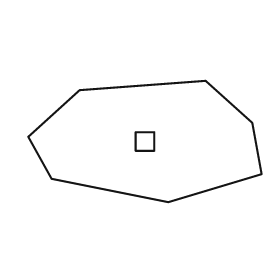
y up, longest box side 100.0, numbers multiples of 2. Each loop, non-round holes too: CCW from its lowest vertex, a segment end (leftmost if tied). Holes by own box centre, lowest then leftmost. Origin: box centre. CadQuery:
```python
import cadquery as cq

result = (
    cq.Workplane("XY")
    .moveTo(10.0, -26.0)
    .lineTo(50.0, -14.0)
    .lineTo(46.0, 8.0)
    .lineTo(26.0, 26.0)
    .lineTo(-28.0, 22.0)
    .lineTo(-50.0, 2.0)
    .lineTo(-40.0, -16.0)
    .close()
    .moveTo(-4.0, -4.0)
    .lineTo(4.0, -4.0)
    .lineTo(4.0, 4.0)
    .lineTo(-4.0, 4.0)
    .close()
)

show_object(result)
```